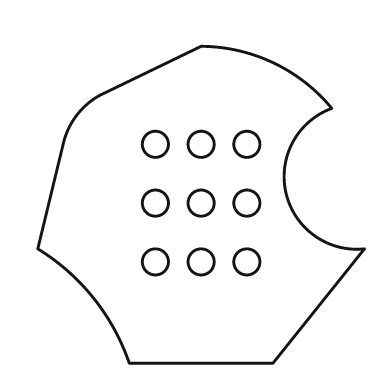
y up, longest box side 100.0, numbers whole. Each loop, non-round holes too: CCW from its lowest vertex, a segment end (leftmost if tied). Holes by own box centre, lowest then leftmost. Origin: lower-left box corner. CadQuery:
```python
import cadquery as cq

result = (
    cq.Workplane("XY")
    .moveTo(28.0, 0.0)
    .lineTo(72.0, 0.0)
    .lineTo(100.0, 35.0)
    .threePointArc((76.0, 52.0), (90.0, 78.0))
    .threePointArc((72.0, 92.0), (50.0, 97.0))
    .lineTo(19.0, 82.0)
    .threePointArc((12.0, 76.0), (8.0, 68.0))
    .lineTo(0.0, 35.0)
    .threePointArc((17.0, 20.0), (28.0, 0.0))
    .close()
    .moveTo(36.0, 31.0)
    .circle(4.0)
    .moveTo(50.0, 31.0)
    .circle(4.0)
    .moveTo(64.0, 31.0)
    .circle(4.0)
    .moveTo(36.0, 49.0)
    .circle(4.0)
    .moveTo(50.0, 49.0)
    .circle(4.0)
    .moveTo(64.0, 49.0)
    .circle(4.0)
    .moveTo(36.0, 67.0)
    .circle(4.0)
    .moveTo(50.0, 67.0)
    .circle(4.0)
    .moveTo(64.0, 67.0)
    .circle(4.0)
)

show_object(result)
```